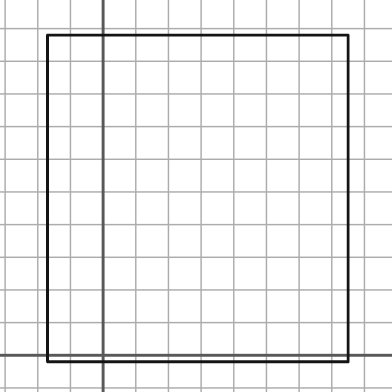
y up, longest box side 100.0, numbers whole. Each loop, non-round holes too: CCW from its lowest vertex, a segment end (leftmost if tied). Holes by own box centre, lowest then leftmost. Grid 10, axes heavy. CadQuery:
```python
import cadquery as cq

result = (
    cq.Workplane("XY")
    .moveTo(-17.0, -2.0)
    .lineTo(75.0, -2.0)
    .lineTo(75.0, 98.0)
    .lineTo(-17.0, 98.0)
    .close()
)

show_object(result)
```